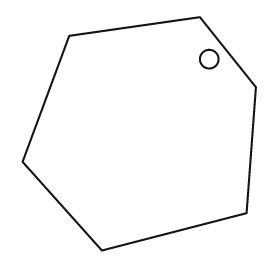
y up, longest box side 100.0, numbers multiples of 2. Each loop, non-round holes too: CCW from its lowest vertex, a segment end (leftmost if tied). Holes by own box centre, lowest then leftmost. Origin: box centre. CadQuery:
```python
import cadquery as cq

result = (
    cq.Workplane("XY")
    .moveTo(-16.0, -50.0)
    .lineTo(46.0, -34.0)
    .lineTo(50.0, 20.0)
    .lineTo(26.0, 50.0)
    .lineTo(-30.0, 42.0)
    .lineTo(-50.0, -12.0)
    .close()
    .moveTo(30.0, 32.0)
    .circle(4.0)
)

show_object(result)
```